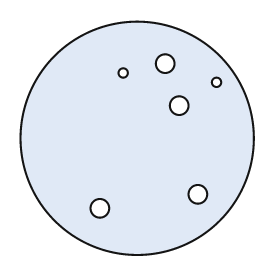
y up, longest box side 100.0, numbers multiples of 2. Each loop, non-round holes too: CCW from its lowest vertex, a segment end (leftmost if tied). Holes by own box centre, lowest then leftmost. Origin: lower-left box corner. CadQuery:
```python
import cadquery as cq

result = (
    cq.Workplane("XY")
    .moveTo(50.0, 50.0)
    .circle(50.0)
    .moveTo(34.0, 20.0)
    .circle(4.0)
    .moveTo(76.0, 26.0)
    .circle(4.0)
    .moveTo(68.0, 64.0)
    .circle(4.0)
    .moveTo(84.0, 74.0)
    .circle(2.0)
    .moveTo(44.0, 78.0)
    .circle(2.0)
    .moveTo(62.0, 82.0)
    .circle(4.0)
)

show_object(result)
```